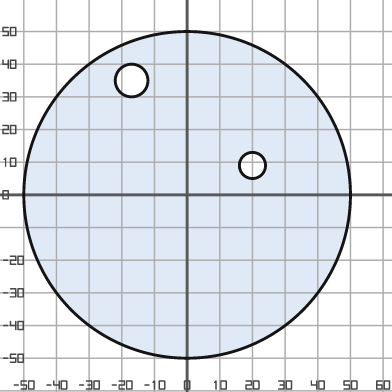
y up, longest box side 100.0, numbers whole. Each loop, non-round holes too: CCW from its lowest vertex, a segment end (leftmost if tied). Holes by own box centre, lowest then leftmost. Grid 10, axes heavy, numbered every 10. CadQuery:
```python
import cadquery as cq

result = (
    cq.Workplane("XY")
    .moveTo(0.0, 0.0)
    .circle(50.0)
    .moveTo(20.0, 9.0)
    .circle(4.0)
    .moveTo(-17.0, 35.0)
    .circle(5.0)
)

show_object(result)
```